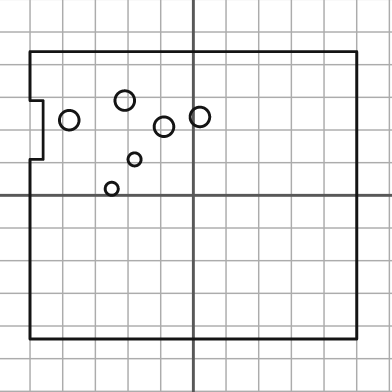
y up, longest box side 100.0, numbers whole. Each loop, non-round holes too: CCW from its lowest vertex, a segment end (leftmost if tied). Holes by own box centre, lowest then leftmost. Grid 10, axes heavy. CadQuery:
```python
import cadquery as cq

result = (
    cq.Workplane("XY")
    .moveTo(-50.0, -44.0)
    .lineTo(50.0, -44.0)
    .lineTo(50.0, 44.0)
    .lineTo(-50.0, 44.0)
    .lineTo(-50.0, 29.0)
    .lineTo(-46.0, 29.0)
    .lineTo(-46.0, 11.0)
    .lineTo(-50.0, 11.0)
    .close()
    .moveTo(-25.0, 2.0)
    .circle(2.0)
    .moveTo(-18.0, 11.0)
    .circle(2.0)
    .moveTo(-9.0, 21.0)
    .circle(3.0)
    .moveTo(-38.0, 23.0)
    .circle(3.0)
    .moveTo(2.0, 24.0)
    .circle(3.0)
    .moveTo(-21.0, 29.0)
    .circle(3.0)
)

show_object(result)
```